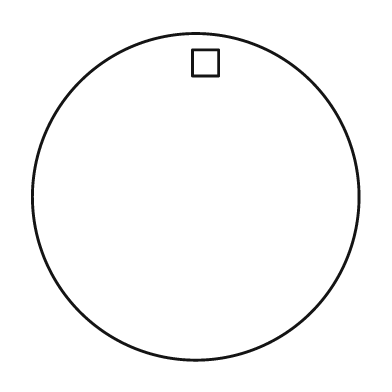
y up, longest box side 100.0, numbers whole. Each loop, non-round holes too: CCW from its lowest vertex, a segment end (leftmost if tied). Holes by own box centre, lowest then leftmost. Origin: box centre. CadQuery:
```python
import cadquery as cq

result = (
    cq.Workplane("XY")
    .moveTo(0.0, 0.0)
    .circle(50.0)
    .moveTo(-1.0, 37.0)
    .lineTo(7.0, 37.0)
    .lineTo(7.0, 45.0)
    .lineTo(-1.0, 45.0)
    .close()
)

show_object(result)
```